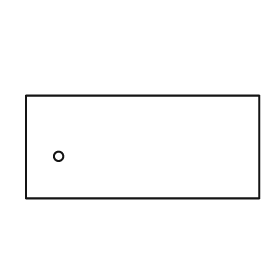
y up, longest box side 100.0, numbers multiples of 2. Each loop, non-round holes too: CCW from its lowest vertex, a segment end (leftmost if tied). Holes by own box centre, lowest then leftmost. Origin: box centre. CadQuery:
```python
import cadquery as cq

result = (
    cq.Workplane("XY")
    .moveTo(-50.0, -22.0)
    .lineTo(50.0, -22.0)
    .lineTo(50.0, 22.0)
    .lineTo(-50.0, 22.0)
    .close()
    .moveTo(-36.0, -4.0)
    .circle(2.0)
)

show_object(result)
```